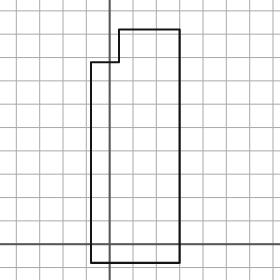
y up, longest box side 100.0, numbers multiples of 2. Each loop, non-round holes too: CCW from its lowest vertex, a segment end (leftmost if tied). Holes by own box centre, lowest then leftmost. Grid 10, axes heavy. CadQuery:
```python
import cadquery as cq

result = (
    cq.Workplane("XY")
    .moveTo(-8.0, -8.0)
    .lineTo(30.0, -8.0)
    .lineTo(30.0, 92.0)
    .lineTo(4.0, 92.0)
    .lineTo(4.0, 78.0)
    .lineTo(-8.0, 78.0)
    .close()
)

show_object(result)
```